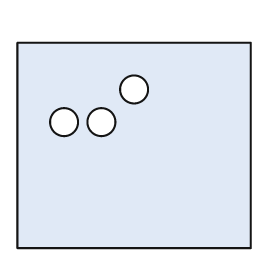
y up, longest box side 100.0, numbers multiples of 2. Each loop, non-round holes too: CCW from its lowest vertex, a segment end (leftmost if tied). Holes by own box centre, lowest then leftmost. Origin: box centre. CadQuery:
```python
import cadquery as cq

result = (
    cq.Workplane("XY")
    .moveTo(-50.0, -44.0)
    .lineTo(50.0, -44.0)
    .lineTo(50.0, 44.0)
    .lineTo(-50.0, 44.0)
    .close()
    .moveTo(-30.0, 10.0)
    .circle(6.0)
    .moveTo(-14.0, 10.0)
    .circle(6.0)
    .moveTo(0.0, 24.0)
    .circle(6.0)
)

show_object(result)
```